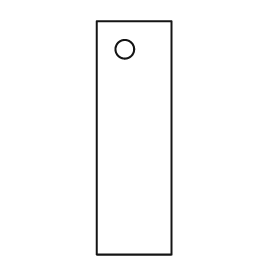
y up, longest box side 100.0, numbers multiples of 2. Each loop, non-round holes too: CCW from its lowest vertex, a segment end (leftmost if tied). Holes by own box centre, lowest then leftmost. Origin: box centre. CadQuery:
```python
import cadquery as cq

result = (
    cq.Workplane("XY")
    .moveTo(-16.0, -50.0)
    .lineTo(16.0, -50.0)
    .lineTo(16.0, 50.0)
    .lineTo(-16.0, 50.0)
    .close()
    .moveTo(-4.0, 38.0)
    .circle(4.0)
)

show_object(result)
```